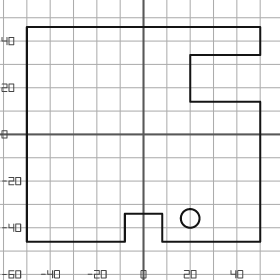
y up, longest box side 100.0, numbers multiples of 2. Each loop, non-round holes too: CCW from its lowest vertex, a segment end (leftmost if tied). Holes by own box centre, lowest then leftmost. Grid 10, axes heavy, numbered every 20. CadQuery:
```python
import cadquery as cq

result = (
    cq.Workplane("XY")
    .moveTo(-50.0, -46.0)
    .lineTo(-8.0, -46.0)
    .lineTo(-8.0, -34.0)
    .lineTo(8.0, -34.0)
    .lineTo(8.0, -46.0)
    .lineTo(50.0, -46.0)
    .lineTo(50.0, 14.0)
    .lineTo(20.0, 14.0)
    .lineTo(20.0, 34.0)
    .lineTo(50.0, 34.0)
    .lineTo(50.0, 46.0)
    .lineTo(-50.0, 46.0)
    .close()
    .moveTo(20.0, -36.0)
    .circle(4.0)
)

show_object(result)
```